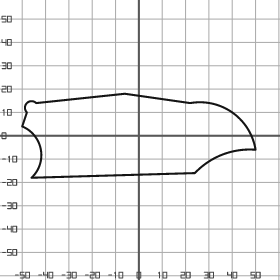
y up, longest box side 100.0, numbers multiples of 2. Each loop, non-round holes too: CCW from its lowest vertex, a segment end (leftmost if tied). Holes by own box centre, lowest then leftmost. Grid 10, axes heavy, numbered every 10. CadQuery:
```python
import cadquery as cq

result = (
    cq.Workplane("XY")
    .moveTo(-46.0, -18.0)
    .lineTo(24.0, -16.0)
    .threePointArc((36.0, -8.0), (50.0, -6.0))
    .threePointArc((40.0, 10.0), (22.0, 14.0))
    .lineTo(-6.0, 18.0)
    .lineTo(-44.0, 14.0)
    .threePointArc((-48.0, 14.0), (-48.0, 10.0))
    .lineTo(-50.0, 4.0)
    .threePointArc((-42.0, -6.0), (-46.0, -18.0))
    .close()
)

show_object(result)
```